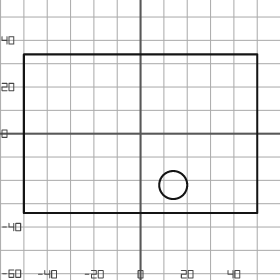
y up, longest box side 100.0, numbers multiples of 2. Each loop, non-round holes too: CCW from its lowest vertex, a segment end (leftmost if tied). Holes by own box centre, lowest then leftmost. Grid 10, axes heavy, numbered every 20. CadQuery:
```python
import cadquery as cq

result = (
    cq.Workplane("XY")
    .moveTo(-50.0, -34.0)
    .lineTo(50.0, -34.0)
    .lineTo(50.0, 34.0)
    .lineTo(-50.0, 34.0)
    .close()
    .moveTo(14.0, -22.0)
    .circle(6.0)
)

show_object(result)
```